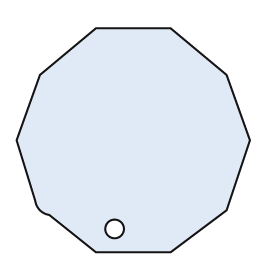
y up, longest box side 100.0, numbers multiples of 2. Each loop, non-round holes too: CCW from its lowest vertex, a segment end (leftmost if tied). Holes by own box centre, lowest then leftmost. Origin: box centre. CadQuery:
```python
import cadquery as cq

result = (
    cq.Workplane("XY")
    .moveTo(-16.0, -48.0)
    .lineTo(16.0, -48.0)
    .lineTo(40.0, -30.0)
    .lineTo(50.0, 0.0)
    .lineTo(40.0, 28.0)
    .lineTo(16.0, 48.0)
    .lineTo(-16.0, 48.0)
    .lineTo(-40.0, 28.0)
    .lineTo(-50.0, 0.0)
    .lineTo(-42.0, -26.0)
    .threePointArc((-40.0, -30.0), (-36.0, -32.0))
    .close()
    .moveTo(-8.0, -38.0)
    .circle(4.0)
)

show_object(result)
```